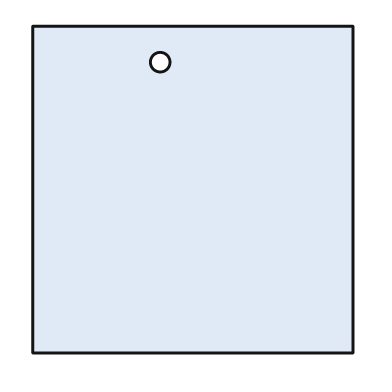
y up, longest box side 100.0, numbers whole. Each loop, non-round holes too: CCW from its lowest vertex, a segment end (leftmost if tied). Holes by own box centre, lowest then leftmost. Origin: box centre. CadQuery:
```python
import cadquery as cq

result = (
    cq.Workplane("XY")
    .moveTo(-49.0, -50.0)
    .lineTo(49.0, -50.0)
    .lineTo(49.0, 50.0)
    .lineTo(-49.0, 50.0)
    .close()
    .moveTo(-10.0, 39.0)
    .circle(3.0)
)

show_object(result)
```